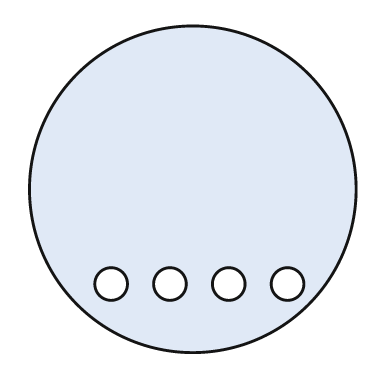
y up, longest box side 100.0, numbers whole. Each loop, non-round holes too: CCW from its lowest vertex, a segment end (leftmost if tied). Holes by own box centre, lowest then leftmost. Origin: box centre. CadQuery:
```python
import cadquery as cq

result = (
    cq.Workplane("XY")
    .moveTo(0.0, 0.0)
    .circle(50.0)
    .moveTo(-25.0, -29.0)
    .circle(5.0)
    .moveTo(-7.0, -29.0)
    .circle(5.0)
    .moveTo(11.0, -29.0)
    .circle(5.0)
    .moveTo(29.0, -29.0)
    .circle(5.0)
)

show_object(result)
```